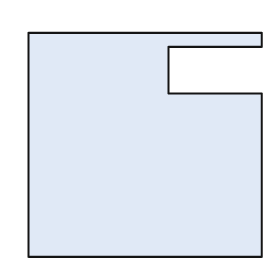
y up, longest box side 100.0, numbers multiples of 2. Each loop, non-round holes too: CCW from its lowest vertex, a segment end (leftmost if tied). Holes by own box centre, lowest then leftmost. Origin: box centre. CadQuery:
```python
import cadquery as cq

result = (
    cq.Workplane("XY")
    .moveTo(-50.0, -48.0)
    .lineTo(50.0, -48.0)
    .lineTo(50.0, 22.0)
    .lineTo(10.0, 22.0)
    .lineTo(10.0, 42.0)
    .lineTo(50.0, 42.0)
    .lineTo(50.0, 48.0)
    .lineTo(-50.0, 48.0)
    .close()
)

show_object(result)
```